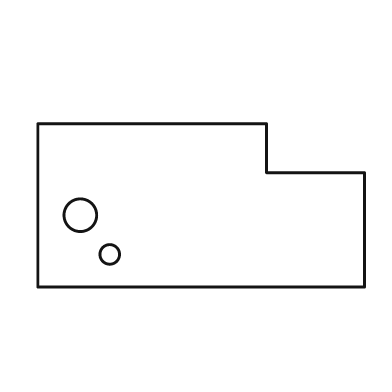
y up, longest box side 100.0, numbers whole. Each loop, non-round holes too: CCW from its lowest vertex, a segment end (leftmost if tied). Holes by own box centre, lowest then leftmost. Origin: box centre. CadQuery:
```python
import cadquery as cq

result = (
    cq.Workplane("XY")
    .moveTo(-50.0, -25.0)
    .lineTo(50.0, -25.0)
    .lineTo(50.0, 10.0)
    .lineTo(20.0, 10.0)
    .lineTo(20.0, 25.0)
    .lineTo(-50.0, 25.0)
    .close()
    .moveTo(-28.0, -15.0)
    .circle(3.0)
    .moveTo(-37.0, -3.0)
    .circle(5.0)
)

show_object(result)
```